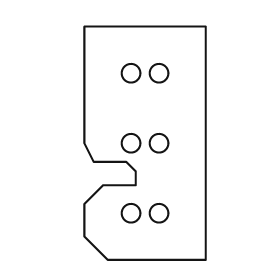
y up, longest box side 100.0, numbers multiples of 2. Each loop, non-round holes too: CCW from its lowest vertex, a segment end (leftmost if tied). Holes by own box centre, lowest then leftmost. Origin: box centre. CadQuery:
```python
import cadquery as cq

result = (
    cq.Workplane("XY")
    .moveTo(-16.0, -50.0)
    .lineTo(26.0, -50.0)
    .lineTo(26.0, 50.0)
    .lineTo(-26.0, 50.0)
    .lineTo(-26.0, 0.0)
    .lineTo(-22.0, -8.0)
    .lineTo(-8.0, -8.0)
    .lineTo(-4.0, -12.0)
    .lineTo(-4.0, -18.0)
    .lineTo(-18.0, -18.0)
    .lineTo(-26.0, -26.0)
    .lineTo(-26.0, -40.0)
    .close()
    .moveTo(-6.0, -30.0)
    .circle(4.0)
    .moveTo(6.0, -30.0)
    .circle(4.0)
    .moveTo(-6.0, 0.0)
    .circle(4.0)
    .moveTo(6.0, 0.0)
    .circle(4.0)
    .moveTo(-6.0, 30.0)
    .circle(4.0)
    .moveTo(6.0, 30.0)
    .circle(4.0)
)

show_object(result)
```